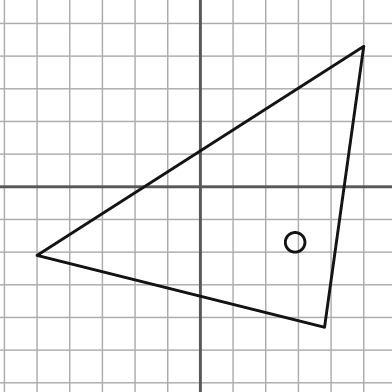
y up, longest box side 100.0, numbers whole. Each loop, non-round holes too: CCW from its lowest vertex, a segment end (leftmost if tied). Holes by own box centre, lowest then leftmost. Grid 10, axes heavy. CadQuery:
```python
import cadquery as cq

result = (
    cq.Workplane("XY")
    .moveTo(38.0, -43.0)
    .lineTo(50.0, 43.0)
    .lineTo(-50.0, -21.0)
    .close()
    .moveTo(29.0, -17.0)
    .circle(3.0)
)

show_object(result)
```